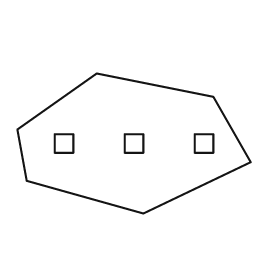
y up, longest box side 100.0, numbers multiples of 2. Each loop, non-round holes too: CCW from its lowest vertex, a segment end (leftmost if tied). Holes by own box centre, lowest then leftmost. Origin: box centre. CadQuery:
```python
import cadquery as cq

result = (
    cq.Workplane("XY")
    .moveTo(4.0, -30.0)
    .lineTo(50.0, -8.0)
    .lineTo(34.0, 20.0)
    .lineTo(-16.0, 30.0)
    .lineTo(-50.0, 6.0)
    .lineTo(-46.0, -16.0)
    .close()
    .moveTo(-34.0, -4.0)
    .lineTo(-26.0, -4.0)
    .lineTo(-26.0, 4.0)
    .lineTo(-34.0, 4.0)
    .close()
    .moveTo(-4.0, -4.0)
    .lineTo(4.0, -4.0)
    .lineTo(4.0, 4.0)
    .lineTo(-4.0, 4.0)
    .close()
    .moveTo(26.0, -4.0)
    .lineTo(34.0, -4.0)
    .lineTo(34.0, 4.0)
    .lineTo(26.0, 4.0)
    .close()
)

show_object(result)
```